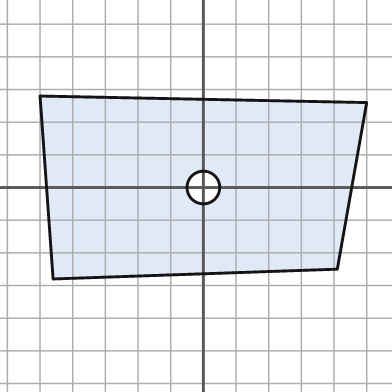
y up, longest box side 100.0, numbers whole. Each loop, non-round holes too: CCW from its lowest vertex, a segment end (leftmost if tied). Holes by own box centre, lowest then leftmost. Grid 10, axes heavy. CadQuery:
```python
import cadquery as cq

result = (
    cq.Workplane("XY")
    .moveTo(-46.0, -28.0)
    .lineTo(41.0, -25.0)
    .lineTo(50.0, 26.0)
    .lineTo(-50.0, 28.0)
    .close()
    .moveTo(0.0, 0.0)
    .circle(5.0)
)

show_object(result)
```